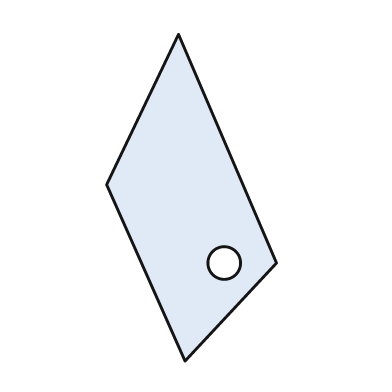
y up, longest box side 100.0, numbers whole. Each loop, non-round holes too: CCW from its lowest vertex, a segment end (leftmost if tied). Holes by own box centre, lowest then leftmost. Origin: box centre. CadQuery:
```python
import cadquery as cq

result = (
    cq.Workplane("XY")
    .moveTo(-2.0, -50.0)
    .lineTo(26.0, -20.0)
    .lineTo(-4.0, 50.0)
    .lineTo(-26.0, 4.0)
    .close()
    .moveTo(10.0, -20.0)
    .circle(5.0)
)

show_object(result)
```